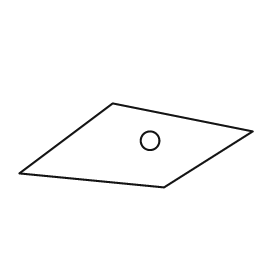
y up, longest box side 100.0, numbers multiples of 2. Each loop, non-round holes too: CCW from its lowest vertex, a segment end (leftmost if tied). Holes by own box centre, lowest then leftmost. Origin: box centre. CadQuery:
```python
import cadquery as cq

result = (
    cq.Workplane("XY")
    .moveTo(12.0, -18.0)
    .lineTo(50.0, 6.0)
    .lineTo(-10.0, 18.0)
    .lineTo(-50.0, -12.0)
    .close()
    .moveTo(6.0, 2.0)
    .circle(4.0)
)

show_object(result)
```